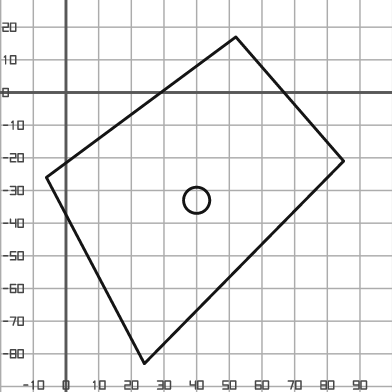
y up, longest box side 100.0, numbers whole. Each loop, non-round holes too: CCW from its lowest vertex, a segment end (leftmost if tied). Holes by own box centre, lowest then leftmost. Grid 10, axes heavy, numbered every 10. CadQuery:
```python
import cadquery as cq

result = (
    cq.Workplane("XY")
    .moveTo(24.0, -83.0)
    .lineTo(85.0, -21.0)
    .lineTo(52.0, 17.0)
    .lineTo(-6.0, -26.0)
    .close()
    .moveTo(40.0, -33.0)
    .circle(4.0)
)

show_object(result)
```